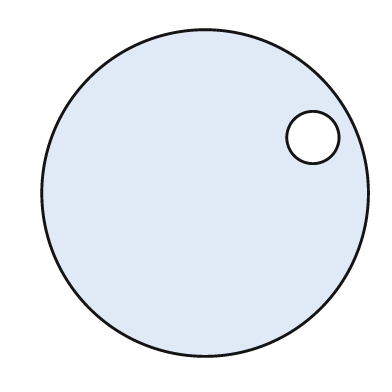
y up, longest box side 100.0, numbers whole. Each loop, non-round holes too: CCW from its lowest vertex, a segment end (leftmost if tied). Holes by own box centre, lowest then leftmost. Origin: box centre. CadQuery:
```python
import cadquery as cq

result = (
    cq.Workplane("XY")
    .moveTo(0.0, 0.0)
    .circle(50.0)
    .moveTo(33.0, 17.0)
    .circle(8.0)
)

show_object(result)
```